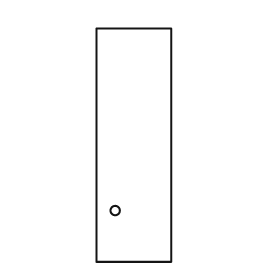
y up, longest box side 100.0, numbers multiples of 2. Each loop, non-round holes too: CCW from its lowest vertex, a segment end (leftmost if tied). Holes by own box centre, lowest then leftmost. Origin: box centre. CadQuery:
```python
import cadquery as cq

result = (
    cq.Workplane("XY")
    .moveTo(-16.0, -50.0)
    .lineTo(16.0, -50.0)
    .lineTo(16.0, 50.0)
    .lineTo(-16.0, 50.0)
    .close()
    .moveTo(-8.0, -28.0)
    .circle(2.0)
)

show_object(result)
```